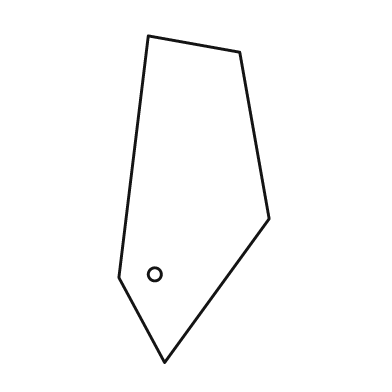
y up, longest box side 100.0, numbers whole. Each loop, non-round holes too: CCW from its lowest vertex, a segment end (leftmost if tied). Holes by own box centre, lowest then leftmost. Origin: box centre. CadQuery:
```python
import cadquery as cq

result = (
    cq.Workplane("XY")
    .moveTo(-9.0, -50.0)
    .lineTo(23.0, -6.0)
    .lineTo(14.0, 45.0)
    .lineTo(-14.0, 50.0)
    .lineTo(-23.0, -24.0)
    .close()
    .moveTo(-12.0, -23.0)
    .circle(2.0)
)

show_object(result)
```